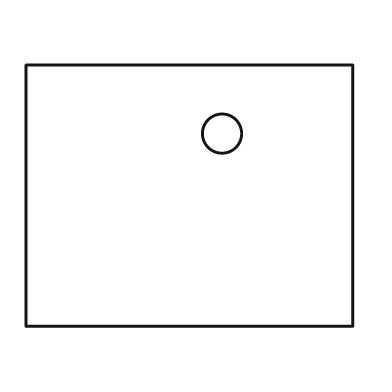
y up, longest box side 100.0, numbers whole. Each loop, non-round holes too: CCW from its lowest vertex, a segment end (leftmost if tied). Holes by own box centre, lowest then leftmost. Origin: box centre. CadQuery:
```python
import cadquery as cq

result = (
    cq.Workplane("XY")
    .moveTo(-50.0, -40.0)
    .lineTo(50.0, -40.0)
    .lineTo(50.0, 40.0)
    .lineTo(-50.0, 40.0)
    .close()
    .moveTo(10.0, 19.0)
    .circle(6.0)
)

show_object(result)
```